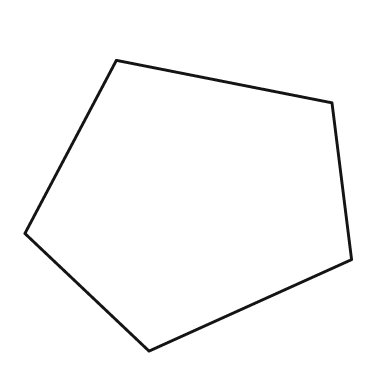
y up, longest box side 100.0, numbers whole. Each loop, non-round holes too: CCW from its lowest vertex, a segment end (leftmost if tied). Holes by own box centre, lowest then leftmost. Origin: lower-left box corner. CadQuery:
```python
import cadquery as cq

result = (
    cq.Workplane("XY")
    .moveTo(38.0, 0.0)
    .lineTo(100.0, 28.0)
    .lineTo(94.0, 76.0)
    .lineTo(28.0, 89.0)
    .lineTo(0.0, 36.0)
    .close()
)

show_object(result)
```